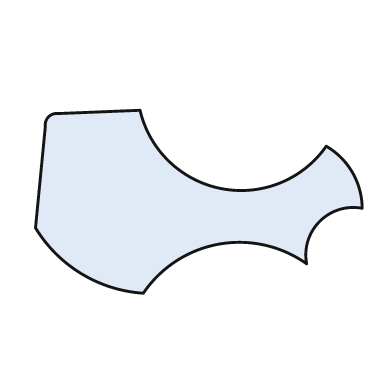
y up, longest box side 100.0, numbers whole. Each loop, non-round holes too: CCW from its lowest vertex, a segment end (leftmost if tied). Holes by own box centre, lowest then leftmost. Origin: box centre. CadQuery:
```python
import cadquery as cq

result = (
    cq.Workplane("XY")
    .moveTo(-17.0, -28.0)
    .threePointArc((6.0, -13.0), (33.0, -19.0))
    .threePointArc((37.0, -6.0), (50.0, -2.0))
    .threePointArc((47.0, 9.0), (39.0, 17.0))
    .threePointArc((7.0, 4.0), (-18.0, 28.0))
    .lineTo(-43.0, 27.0)
    .threePointArc((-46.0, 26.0), (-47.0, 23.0))
    .lineTo(-50.0, -8.0)
    .threePointArc((-36.0, -22.0), (-17.0, -28.0))
    .close()
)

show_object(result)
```